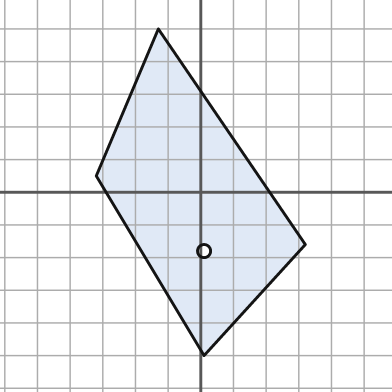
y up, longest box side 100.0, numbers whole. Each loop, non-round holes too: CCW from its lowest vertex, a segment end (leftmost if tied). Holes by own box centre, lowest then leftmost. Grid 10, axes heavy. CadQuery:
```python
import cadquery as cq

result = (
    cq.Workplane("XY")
    .moveTo(1.0, -50.0)
    .lineTo(32.0, -16.0)
    .lineTo(-13.0, 50.0)
    .lineTo(-32.0, 5.0)
    .close()
    .moveTo(1.0, -18.0)
    .circle(2.0)
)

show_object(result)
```